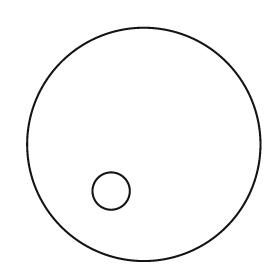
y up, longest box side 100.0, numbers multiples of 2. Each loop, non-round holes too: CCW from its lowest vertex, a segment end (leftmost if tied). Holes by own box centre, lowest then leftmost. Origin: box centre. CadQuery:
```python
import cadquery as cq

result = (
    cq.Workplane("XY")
    .moveTo(0.0, 0.0)
    .circle(50.0)
    .moveTo(-14.0, -20.0)
    .circle(8.0)
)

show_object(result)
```